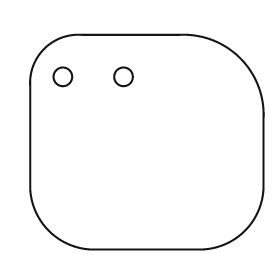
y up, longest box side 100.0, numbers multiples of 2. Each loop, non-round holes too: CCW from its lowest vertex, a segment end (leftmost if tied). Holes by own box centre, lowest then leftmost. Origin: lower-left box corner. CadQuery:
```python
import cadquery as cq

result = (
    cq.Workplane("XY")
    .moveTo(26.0, 0.0)
    .lineTo(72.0, 0.0)
    .threePointArc((92.0, 8.0), (100.0, 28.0))
    .lineTo(100.0, 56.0)
    .threePointArc((90.0, 82.0), (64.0, 92.0))
    .lineTo(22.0, 92.0)
    .threePointArc((6.0, 86.0), (0.0, 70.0))
    .lineTo(0.0, 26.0)
    .threePointArc((8.0, 8.0), (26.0, 0.0))
    .close()
    .moveTo(14.0, 74.0)
    .circle(4.0)
    .moveTo(40.0, 74.0)
    .circle(4.0)
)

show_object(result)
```